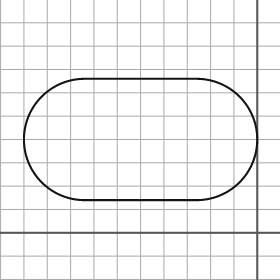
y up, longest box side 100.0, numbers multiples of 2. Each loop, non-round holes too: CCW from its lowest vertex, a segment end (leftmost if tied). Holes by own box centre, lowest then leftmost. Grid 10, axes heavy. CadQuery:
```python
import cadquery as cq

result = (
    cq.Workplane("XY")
    .moveTo(-74.0, 14.0)
    .lineTo(-26.0, 14.0)
    .threePointArc((0.0, 40.0), (-26.0, 66.0))
    .lineTo(-74.0, 66.0)
    .threePointArc((-100.0, 40.0), (-74.0, 14.0))
    .close()
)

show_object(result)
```